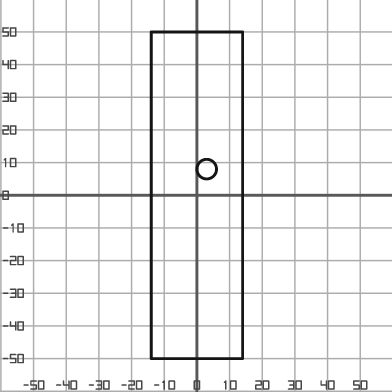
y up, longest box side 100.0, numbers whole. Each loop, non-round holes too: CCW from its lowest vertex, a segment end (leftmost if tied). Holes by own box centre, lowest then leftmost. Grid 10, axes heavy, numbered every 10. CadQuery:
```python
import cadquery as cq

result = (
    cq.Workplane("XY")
    .moveTo(-14.0, -50.0)
    .lineTo(14.0, -50.0)
    .lineTo(14.0, 50.0)
    .lineTo(-14.0, 50.0)
    .close()
    .moveTo(3.0, 8.0)
    .circle(3.0)
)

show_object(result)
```